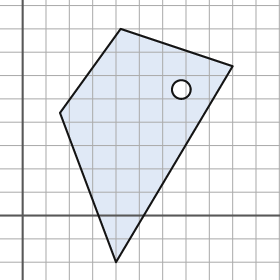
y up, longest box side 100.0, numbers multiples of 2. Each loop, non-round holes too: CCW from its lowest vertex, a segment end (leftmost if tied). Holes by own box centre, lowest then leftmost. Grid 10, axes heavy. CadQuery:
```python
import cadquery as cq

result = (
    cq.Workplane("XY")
    .moveTo(40.0, -20.0)
    .lineTo(90.0, 64.0)
    .lineTo(42.0, 80.0)
    .lineTo(16.0, 44.0)
    .close()
    .moveTo(68.0, 54.0)
    .circle(4.0)
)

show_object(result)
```